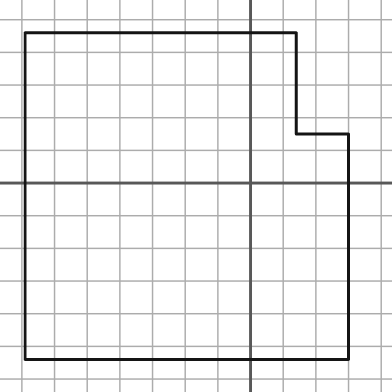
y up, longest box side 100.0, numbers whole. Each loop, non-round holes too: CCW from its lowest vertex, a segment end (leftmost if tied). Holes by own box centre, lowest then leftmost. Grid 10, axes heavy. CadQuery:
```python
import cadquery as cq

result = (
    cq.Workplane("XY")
    .moveTo(-69.0, -54.0)
    .lineTo(30.0, -54.0)
    .lineTo(30.0, 15.0)
    .lineTo(14.0, 15.0)
    .lineTo(14.0, 46.0)
    .lineTo(-69.0, 46.0)
    .close()
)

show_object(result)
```